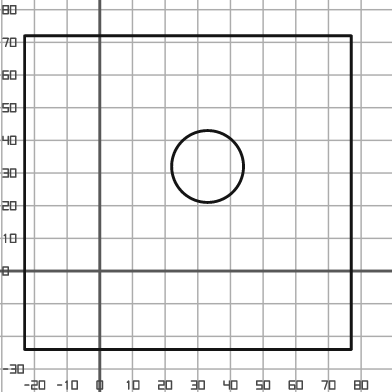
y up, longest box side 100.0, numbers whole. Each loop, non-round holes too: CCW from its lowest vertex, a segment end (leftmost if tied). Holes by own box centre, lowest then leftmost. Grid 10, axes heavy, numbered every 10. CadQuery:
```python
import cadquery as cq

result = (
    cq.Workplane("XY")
    .moveTo(-23.0, -24.0)
    .lineTo(77.0, -24.0)
    .lineTo(77.0, 72.0)
    .lineTo(-23.0, 72.0)
    .close()
    .moveTo(33.0, 32.0)
    .circle(11.0)
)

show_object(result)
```